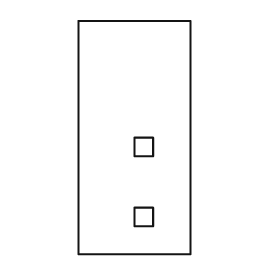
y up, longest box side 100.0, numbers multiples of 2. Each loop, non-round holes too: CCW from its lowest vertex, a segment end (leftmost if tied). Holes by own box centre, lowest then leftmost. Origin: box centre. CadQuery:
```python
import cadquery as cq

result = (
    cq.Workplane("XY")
    .moveTo(-24.0, -50.0)
    .lineTo(24.0, -50.0)
    .lineTo(24.0, 50.0)
    .lineTo(-24.0, 50.0)
    .close()
    .moveTo(0.0, -38.0)
    .lineTo(8.0, -38.0)
    .lineTo(8.0, -30.0)
    .lineTo(0.0, -30.0)
    .close()
    .moveTo(0.0, -8.0)
    .lineTo(8.0, -8.0)
    .lineTo(8.0, 0.0)
    .lineTo(0.0, 0.0)
    .close()
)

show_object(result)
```